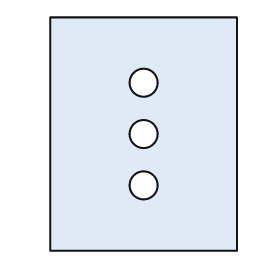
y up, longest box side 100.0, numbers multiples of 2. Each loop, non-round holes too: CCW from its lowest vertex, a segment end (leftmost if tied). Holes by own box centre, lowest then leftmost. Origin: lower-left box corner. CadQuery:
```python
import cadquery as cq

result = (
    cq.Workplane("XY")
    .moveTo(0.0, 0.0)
    .lineTo(80.0, 0.0)
    .lineTo(80.0, 100.0)
    .lineTo(0.0, 100.0)
    .close()
    .moveTo(40.0, 28.0)
    .circle(6.0)
    .moveTo(40.0, 50.0)
    .circle(6.0)
    .moveTo(40.0, 72.0)
    .circle(6.0)
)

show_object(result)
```